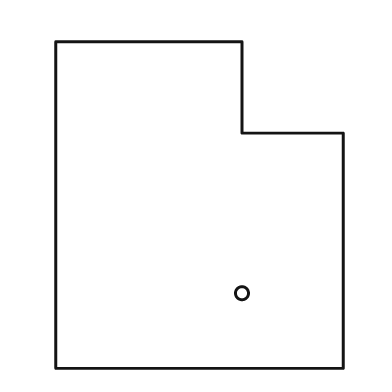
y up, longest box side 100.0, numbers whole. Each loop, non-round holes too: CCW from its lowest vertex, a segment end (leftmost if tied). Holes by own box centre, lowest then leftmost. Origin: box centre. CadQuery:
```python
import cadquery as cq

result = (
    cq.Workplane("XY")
    .moveTo(-44.0, -50.0)
    .lineTo(44.0, -50.0)
    .lineTo(44.0, 22.0)
    .lineTo(13.0, 22.0)
    .lineTo(13.0, 50.0)
    .lineTo(-44.0, 50.0)
    .close()
    .moveTo(13.0, -27.0)
    .circle(2.0)
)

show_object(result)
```